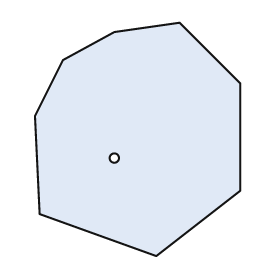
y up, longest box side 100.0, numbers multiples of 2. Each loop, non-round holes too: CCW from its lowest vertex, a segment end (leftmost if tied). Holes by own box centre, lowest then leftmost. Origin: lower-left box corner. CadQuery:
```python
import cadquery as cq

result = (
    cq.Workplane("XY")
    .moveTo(52.0, 0.0)
    .lineTo(88.0, 28.0)
    .lineTo(88.0, 74.0)
    .lineTo(62.0, 100.0)
    .lineTo(34.0, 96.0)
    .lineTo(12.0, 84.0)
    .lineTo(0.0, 60.0)
    .lineTo(2.0, 18.0)
    .close()
    .moveTo(34.0, 42.0)
    .circle(2.0)
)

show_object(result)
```